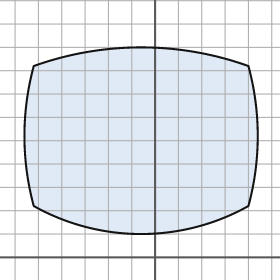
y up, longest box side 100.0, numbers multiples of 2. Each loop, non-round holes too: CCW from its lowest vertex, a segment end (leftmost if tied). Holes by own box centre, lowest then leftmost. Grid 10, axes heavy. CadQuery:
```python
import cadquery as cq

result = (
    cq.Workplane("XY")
    .moveTo(-52.0, 22.0)
    .threePointArc((-6.0, 10.0), (40.0, 22.0))
    .threePointArc((44.0, 52.0), (40.0, 82.0))
    .threePointArc((-6.0, 90.0), (-52.0, 82.0))
    .threePointArc((-56.0, 52.0), (-52.0, 22.0))
    .close()
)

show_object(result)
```